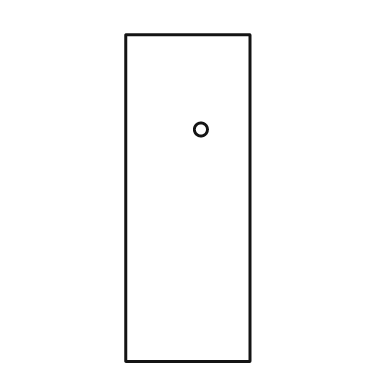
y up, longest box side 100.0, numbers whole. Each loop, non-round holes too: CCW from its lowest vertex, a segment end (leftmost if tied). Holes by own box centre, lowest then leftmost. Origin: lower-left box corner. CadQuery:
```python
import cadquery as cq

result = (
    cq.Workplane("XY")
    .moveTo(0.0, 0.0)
    .lineTo(38.0, 0.0)
    .lineTo(38.0, 100.0)
    .lineTo(0.0, 100.0)
    .close()
    .moveTo(23.0, 71.0)
    .circle(2.0)
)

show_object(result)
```